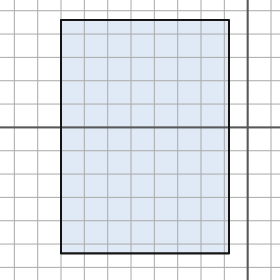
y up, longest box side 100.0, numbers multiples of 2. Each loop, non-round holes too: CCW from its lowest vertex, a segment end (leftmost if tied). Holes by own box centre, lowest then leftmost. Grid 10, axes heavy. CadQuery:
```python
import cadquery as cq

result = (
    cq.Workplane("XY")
    .moveTo(-80.0, -54.0)
    .lineTo(-8.0, -54.0)
    .lineTo(-8.0, 46.0)
    .lineTo(-80.0, 46.0)
    .close()
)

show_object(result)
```